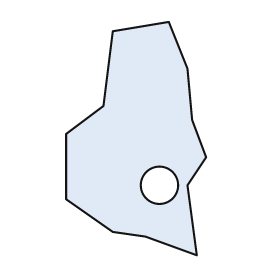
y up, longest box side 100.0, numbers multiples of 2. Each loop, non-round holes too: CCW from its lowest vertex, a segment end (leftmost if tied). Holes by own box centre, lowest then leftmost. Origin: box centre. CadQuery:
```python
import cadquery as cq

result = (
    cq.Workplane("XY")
    .moveTo(26.0, -50.0)
    .lineTo(22.0, -20.0)
    .lineTo(30.0, -8.0)
    .lineTo(24.0, 8.0)
    .lineTo(22.0, 30.0)
    .lineTo(14.0, 50.0)
    .lineTo(-10.0, 46.0)
    .lineTo(-14.0, 14.0)
    .lineTo(-30.0, 2.0)
    .lineTo(-30.0, -26.0)
    .lineTo(-10.0, -40.0)
    .lineTo(4.0, -42.0)
    .close()
    .moveTo(10.0, -20.0)
    .circle(8.0)
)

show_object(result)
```